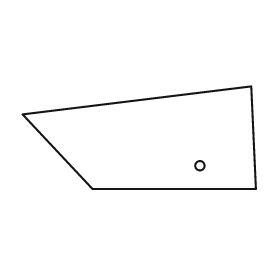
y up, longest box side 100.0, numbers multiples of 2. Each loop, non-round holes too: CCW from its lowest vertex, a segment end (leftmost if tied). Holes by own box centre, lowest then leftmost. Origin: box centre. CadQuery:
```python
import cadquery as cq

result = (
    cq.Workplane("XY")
    .moveTo(-20.0, -22.0)
    .lineTo(50.0, -22.0)
    .lineTo(48.0, 22.0)
    .lineTo(-50.0, 10.0)
    .close()
    .moveTo(26.0, -12.0)
    .circle(2.0)
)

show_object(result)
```